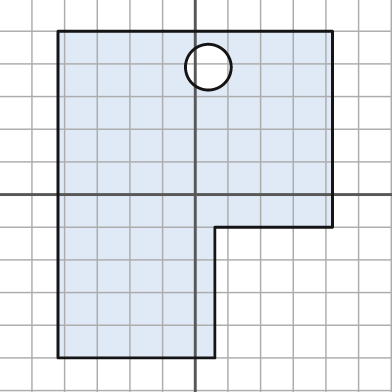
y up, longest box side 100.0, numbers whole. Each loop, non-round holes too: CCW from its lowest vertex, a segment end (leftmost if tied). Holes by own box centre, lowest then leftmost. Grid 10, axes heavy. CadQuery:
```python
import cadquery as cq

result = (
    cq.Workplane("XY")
    .moveTo(-42.0, -50.0)
    .lineTo(6.0, -50.0)
    .lineTo(6.0, -10.0)
    .lineTo(42.0, -10.0)
    .lineTo(42.0, 50.0)
    .lineTo(-42.0, 50.0)
    .close()
    .moveTo(4.0, 39.0)
    .circle(7.0)
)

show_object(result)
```